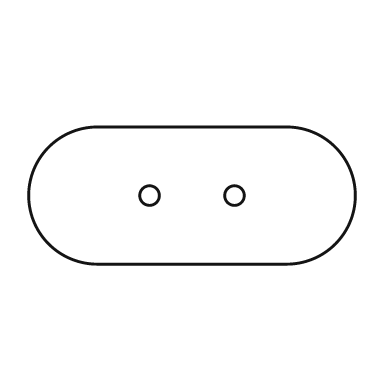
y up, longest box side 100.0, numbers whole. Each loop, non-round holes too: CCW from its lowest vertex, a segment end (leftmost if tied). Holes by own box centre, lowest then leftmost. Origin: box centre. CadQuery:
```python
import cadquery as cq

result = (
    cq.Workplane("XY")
    .moveTo(-29.0, -21.0)
    .lineTo(29.0, -21.0)
    .threePointArc((50.0, 0.0), (29.0, 21.0))
    .lineTo(-29.0, 21.0)
    .threePointArc((-50.0, 0.0), (-29.0, -21.0))
    .close()
    .moveTo(-13.0, 0.0)
    .circle(3.0)
    .moveTo(13.0, 0.0)
    .circle(3.0)
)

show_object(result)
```